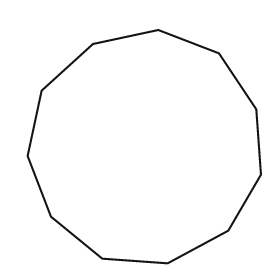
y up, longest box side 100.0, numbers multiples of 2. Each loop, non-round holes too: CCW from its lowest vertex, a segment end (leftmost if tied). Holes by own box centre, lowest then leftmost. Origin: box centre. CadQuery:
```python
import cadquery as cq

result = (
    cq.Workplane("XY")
    .moveTo(10.0, -50.0)
    .lineTo(36.0, -36.0)
    .lineTo(50.0, -12.0)
    .lineTo(48.0, 16.0)
    .lineTo(32.0, 40.0)
    .lineTo(6.0, 50.0)
    .lineTo(-22.0, 44.0)
    .lineTo(-44.0, 24.0)
    .lineTo(-50.0, -4.0)
    .lineTo(-40.0, -30.0)
    .lineTo(-18.0, -48.0)
    .close()
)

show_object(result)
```